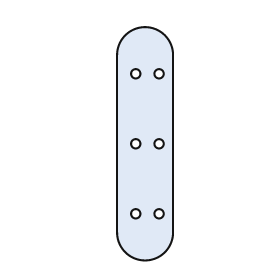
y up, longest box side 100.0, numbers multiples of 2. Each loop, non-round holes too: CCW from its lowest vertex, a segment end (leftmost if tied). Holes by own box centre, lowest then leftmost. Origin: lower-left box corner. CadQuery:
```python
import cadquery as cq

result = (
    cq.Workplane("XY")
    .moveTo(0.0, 12.0)
    .threePointArc((12.0, 0.0), (24.0, 12.0))
    .lineTo(24.0, 88.0)
    .threePointArc((12.0, 100.0), (0.0, 88.0))
    .close()
    .moveTo(8.0, 20.0)
    .circle(2.0)
    .moveTo(18.0, 20.0)
    .circle(2.0)
    .moveTo(8.0, 50.0)
    .circle(2.0)
    .moveTo(18.0, 50.0)
    .circle(2.0)
    .moveTo(8.0, 80.0)
    .circle(2.0)
    .moveTo(18.0, 80.0)
    .circle(2.0)
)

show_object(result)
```